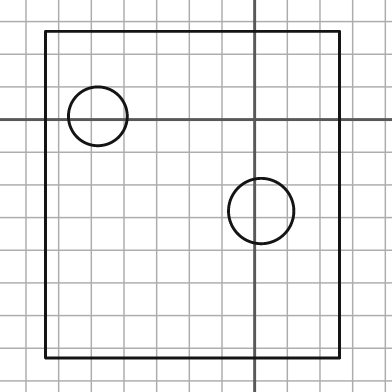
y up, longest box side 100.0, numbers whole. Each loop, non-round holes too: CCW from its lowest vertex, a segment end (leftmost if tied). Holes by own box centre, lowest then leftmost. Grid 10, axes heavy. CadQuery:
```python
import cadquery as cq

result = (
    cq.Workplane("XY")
    .moveTo(-64.0, -73.0)
    .lineTo(26.0, -73.0)
    .lineTo(26.0, 27.0)
    .lineTo(-64.0, 27.0)
    .close()
    .moveTo(2.0, -28.0)
    .circle(10.0)
    .moveTo(-48.0, 1.0)
    .circle(9.0)
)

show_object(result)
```